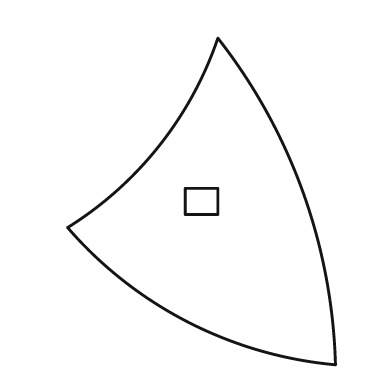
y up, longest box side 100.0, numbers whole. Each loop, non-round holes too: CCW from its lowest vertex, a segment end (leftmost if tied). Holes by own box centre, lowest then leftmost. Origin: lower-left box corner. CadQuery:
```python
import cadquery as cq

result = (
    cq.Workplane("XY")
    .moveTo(82.0, 0.0)
    .threePointArc((72.0, 53.0), (46.0, 100.0))
    .threePointArc((28.0, 67.0), (0.0, 42.0))
    .threePointArc((37.0, 13.0), (82.0, 0.0))
    .close()
    .moveTo(36.0, 46.0)
    .lineTo(46.0, 46.0)
    .lineTo(46.0, 54.0)
    .lineTo(36.0, 54.0)
    .close()
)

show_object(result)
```